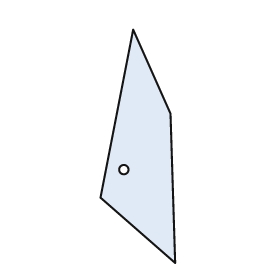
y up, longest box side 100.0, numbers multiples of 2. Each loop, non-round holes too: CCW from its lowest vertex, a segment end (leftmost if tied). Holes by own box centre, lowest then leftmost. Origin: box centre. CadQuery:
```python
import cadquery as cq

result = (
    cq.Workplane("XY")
    .moveTo(16.0, -50.0)
    .lineTo(14.0, 14.0)
    .lineTo(-2.0, 50.0)
    .lineTo(-16.0, -22.0)
    .close()
    .moveTo(-6.0, -10.0)
    .circle(2.0)
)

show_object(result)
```